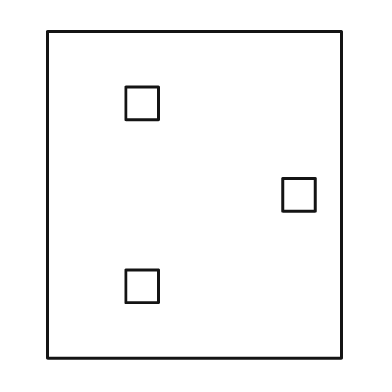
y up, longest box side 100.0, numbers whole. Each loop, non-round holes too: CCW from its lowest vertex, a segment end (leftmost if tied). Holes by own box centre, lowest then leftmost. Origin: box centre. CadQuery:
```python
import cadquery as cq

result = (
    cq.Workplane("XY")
    .moveTo(-45.0, -50.0)
    .lineTo(45.0, -50.0)
    .lineTo(45.0, 50.0)
    .lineTo(-45.0, 50.0)
    .close()
    .moveTo(-21.0, -33.0)
    .lineTo(-11.0, -33.0)
    .lineTo(-11.0, -23.0)
    .lineTo(-21.0, -23.0)
    .close()
    .moveTo(27.0, -5.0)
    .lineTo(37.0, -5.0)
    .lineTo(37.0, 5.0)
    .lineTo(27.0, 5.0)
    .close()
    .moveTo(-21.0, 23.0)
    .lineTo(-11.0, 23.0)
    .lineTo(-11.0, 33.0)
    .lineTo(-21.0, 33.0)
    .close()
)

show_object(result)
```